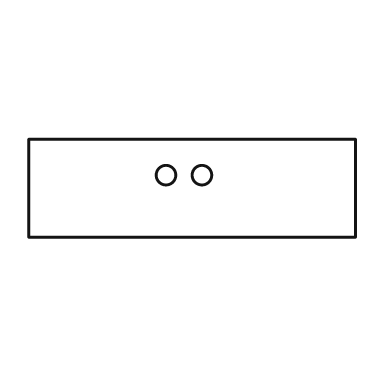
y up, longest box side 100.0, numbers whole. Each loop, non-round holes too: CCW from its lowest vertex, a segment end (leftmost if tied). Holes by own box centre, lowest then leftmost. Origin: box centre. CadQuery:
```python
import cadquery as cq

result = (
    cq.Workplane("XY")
    .moveTo(-50.0, -15.0)
    .lineTo(50.0, -15.0)
    .lineTo(50.0, 15.0)
    .lineTo(-50.0, 15.0)
    .close()
    .moveTo(-8.0, 4.0)
    .circle(3.0)
    .moveTo(3.0, 4.0)
    .circle(3.0)
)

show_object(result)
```